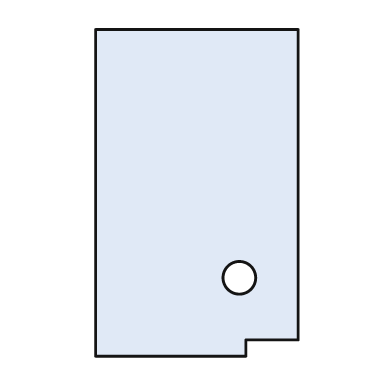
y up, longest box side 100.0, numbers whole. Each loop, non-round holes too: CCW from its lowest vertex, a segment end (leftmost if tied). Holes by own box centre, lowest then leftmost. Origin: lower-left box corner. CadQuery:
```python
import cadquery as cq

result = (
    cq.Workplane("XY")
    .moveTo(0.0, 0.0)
    .lineTo(46.0, 0.0)
    .lineTo(46.0, 5.0)
    .lineTo(62.0, 5.0)
    .lineTo(62.0, 100.0)
    .lineTo(0.0, 100.0)
    .close()
    .moveTo(44.0, 24.0)
    .circle(5.0)
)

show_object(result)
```